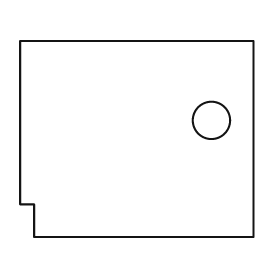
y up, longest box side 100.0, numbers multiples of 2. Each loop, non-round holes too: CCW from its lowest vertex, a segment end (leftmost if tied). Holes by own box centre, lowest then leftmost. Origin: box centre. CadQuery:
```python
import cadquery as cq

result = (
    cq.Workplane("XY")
    .moveTo(-44.0, -42.0)
    .lineTo(50.0, -42.0)
    .lineTo(50.0, 42.0)
    .lineTo(-50.0, 42.0)
    .lineTo(-50.0, -28.0)
    .lineTo(-44.0, -28.0)
    .close()
    .moveTo(32.0, 8.0)
    .circle(8.0)
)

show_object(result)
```